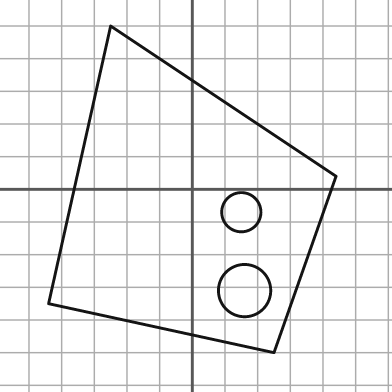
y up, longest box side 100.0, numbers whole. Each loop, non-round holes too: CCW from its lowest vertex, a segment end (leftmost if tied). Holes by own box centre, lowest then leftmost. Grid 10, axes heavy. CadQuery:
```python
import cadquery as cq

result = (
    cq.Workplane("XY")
    .moveTo(25.0, -50.0)
    .lineTo(44.0, 4.0)
    .lineTo(-25.0, 50.0)
    .lineTo(-44.0, -35.0)
    .close()
    .moveTo(16.0, -31.0)
    .circle(8.0)
    .moveTo(15.0, -7.0)
    .circle(6.0)
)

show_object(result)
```